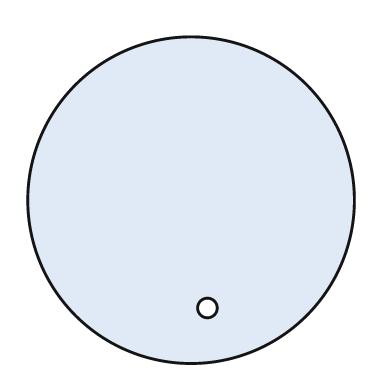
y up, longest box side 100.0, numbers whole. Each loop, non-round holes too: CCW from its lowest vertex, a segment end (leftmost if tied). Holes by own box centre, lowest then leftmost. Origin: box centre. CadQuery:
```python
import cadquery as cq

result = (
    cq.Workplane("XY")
    .moveTo(0.0, 0.0)
    .circle(50.0)
    .moveTo(5.0, -33.0)
    .circle(3.0)
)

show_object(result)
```